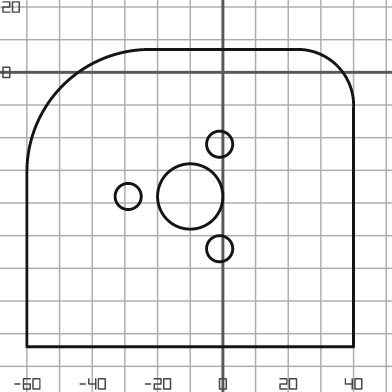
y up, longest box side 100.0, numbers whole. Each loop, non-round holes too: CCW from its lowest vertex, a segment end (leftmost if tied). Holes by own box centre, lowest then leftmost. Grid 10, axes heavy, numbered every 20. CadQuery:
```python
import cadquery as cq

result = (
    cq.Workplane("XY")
    .moveTo(-60.0, -84.0)
    .lineTo(40.0, -84.0)
    .lineTo(40.0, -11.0)
    .threePointArc((35.0, 2.0), (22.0, 7.0))
    .lineTo(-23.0, 7.0)
    .threePointArc((-49.0, -4.0), (-60.0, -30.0))
    .close()
    .moveTo(-1.0, -54.0)
    .circle(4.0)
    .moveTo(-29.0, -38.0)
    .circle(4.0)
    .moveTo(-10.0, -38.0)
    .circle(10.0)
    .moveTo(-1.0, -22.0)
    .circle(4.0)
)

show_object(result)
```